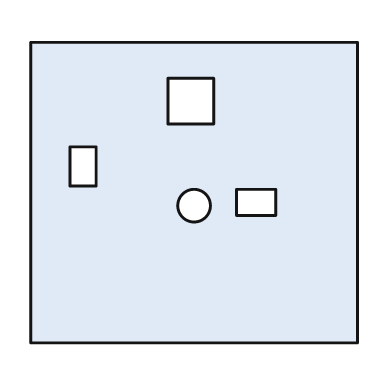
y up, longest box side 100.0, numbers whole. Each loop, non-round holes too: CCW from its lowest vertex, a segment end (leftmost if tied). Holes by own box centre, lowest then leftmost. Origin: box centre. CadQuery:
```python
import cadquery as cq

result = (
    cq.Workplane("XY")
    .moveTo(-50.0, -46.0)
    .lineTo(50.0, -46.0)
    .lineTo(50.0, 46.0)
    .lineTo(-50.0, 46.0)
    .close()
    .moveTo(0.0, -4.0)
    .circle(5.0)
    .moveTo(13.0, -7.0)
    .lineTo(25.0, -7.0)
    .lineTo(25.0, 1.0)
    .lineTo(13.0, 1.0)
    .close()
    .moveTo(-38.0, 2.0)
    .lineTo(-30.0, 2.0)
    .lineTo(-30.0, 14.0)
    .lineTo(-38.0, 14.0)
    .close()
    .moveTo(-8.0, 21.0)
    .lineTo(6.0, 21.0)
    .lineTo(6.0, 35.0)
    .lineTo(-8.0, 35.0)
    .close()
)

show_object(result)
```